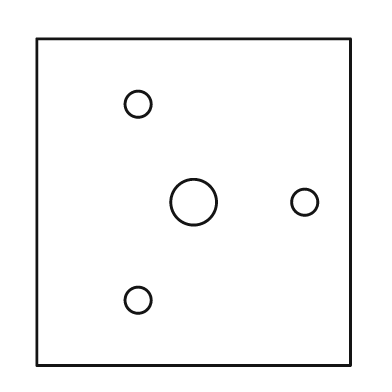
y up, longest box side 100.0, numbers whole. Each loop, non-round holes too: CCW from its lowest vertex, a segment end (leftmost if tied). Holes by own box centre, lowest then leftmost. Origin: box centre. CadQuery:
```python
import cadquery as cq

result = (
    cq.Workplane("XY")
    .moveTo(-48.0, -50.0)
    .lineTo(48.0, -50.0)
    .lineTo(48.0, 50.0)
    .lineTo(-48.0, 50.0)
    .close()
    .moveTo(-17.0, -30.0)
    .circle(4.0)
    .moveTo(0.0, 0.0)
    .circle(7.0)
    .moveTo(34.0, 0.0)
    .circle(4.0)
    .moveTo(-17.0, 30.0)
    .circle(4.0)
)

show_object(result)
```